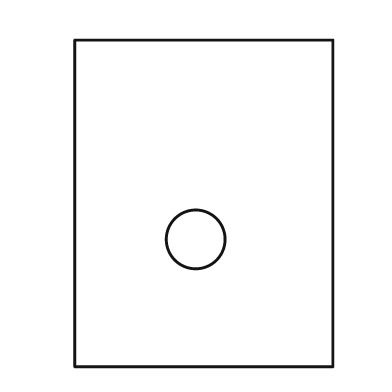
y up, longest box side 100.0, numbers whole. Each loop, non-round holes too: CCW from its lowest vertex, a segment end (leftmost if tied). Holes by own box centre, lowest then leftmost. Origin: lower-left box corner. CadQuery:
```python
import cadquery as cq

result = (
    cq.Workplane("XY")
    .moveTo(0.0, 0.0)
    .lineTo(79.0, 0.0)
    .lineTo(79.0, 100.0)
    .lineTo(0.0, 100.0)
    .close()
    .moveTo(37.0, 39.0)
    .circle(9.0)
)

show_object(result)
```